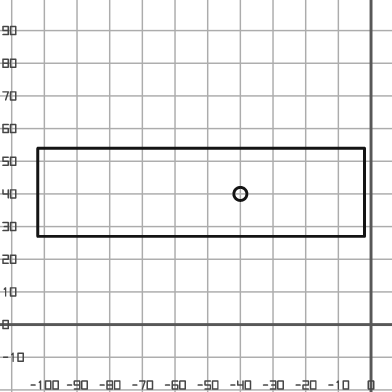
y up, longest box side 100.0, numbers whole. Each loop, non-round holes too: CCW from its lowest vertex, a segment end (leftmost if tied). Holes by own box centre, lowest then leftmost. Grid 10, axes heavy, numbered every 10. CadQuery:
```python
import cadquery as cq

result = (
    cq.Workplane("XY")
    .moveTo(-102.0, 27.0)
    .lineTo(-2.0, 27.0)
    .lineTo(-2.0, 54.0)
    .lineTo(-102.0, 54.0)
    .close()
    .moveTo(-40.0, 40.0)
    .circle(2.0)
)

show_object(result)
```